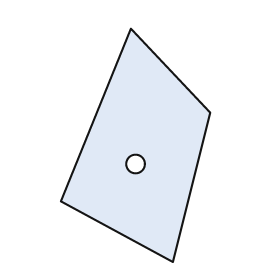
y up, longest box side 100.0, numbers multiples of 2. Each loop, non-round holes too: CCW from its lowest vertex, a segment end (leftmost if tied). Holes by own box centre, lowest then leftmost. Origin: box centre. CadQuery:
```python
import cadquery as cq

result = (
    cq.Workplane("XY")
    .moveTo(16.0, -50.0)
    .lineTo(32.0, 14.0)
    .lineTo(-2.0, 50.0)
    .lineTo(-32.0, -24.0)
    .close()
    .moveTo(0.0, -8.0)
    .circle(4.0)
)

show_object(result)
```